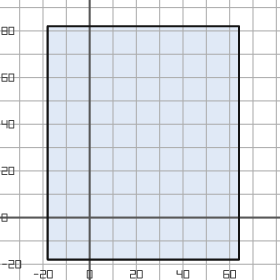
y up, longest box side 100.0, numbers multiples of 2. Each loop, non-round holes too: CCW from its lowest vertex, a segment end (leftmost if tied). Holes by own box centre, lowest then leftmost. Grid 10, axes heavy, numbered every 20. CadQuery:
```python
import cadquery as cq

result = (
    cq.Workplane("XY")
    .moveTo(-18.0, -18.0)
    .lineTo(64.0, -18.0)
    .lineTo(64.0, 82.0)
    .lineTo(-18.0, 82.0)
    .close()
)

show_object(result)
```